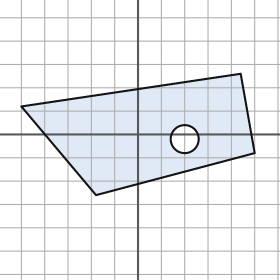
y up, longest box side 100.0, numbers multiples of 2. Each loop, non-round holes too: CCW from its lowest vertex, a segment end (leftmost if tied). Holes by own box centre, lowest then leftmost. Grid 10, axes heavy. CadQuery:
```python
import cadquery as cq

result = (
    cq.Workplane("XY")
    .moveTo(-18.0, -26.0)
    .lineTo(50.0, -8.0)
    .lineTo(44.0, 26.0)
    .lineTo(-50.0, 12.0)
    .close()
    .moveTo(20.0, -2.0)
    .circle(6.0)
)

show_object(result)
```